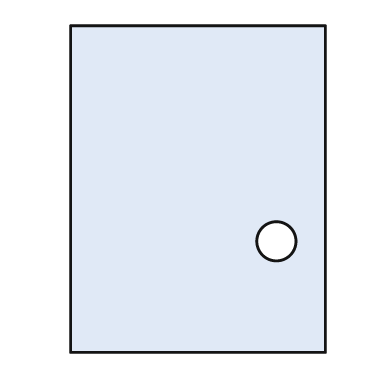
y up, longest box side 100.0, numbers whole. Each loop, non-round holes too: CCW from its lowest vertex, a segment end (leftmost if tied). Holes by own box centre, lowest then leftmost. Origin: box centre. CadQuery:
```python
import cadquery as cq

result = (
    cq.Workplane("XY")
    .moveTo(-39.0, -50.0)
    .lineTo(39.0, -50.0)
    .lineTo(39.0, 50.0)
    .lineTo(-39.0, 50.0)
    .close()
    .moveTo(24.0, -16.0)
    .circle(6.0)
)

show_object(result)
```